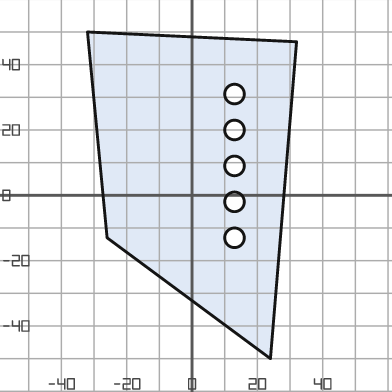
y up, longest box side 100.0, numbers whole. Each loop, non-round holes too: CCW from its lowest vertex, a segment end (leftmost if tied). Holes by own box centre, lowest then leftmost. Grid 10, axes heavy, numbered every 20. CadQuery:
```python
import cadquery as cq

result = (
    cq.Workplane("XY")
    .moveTo(24.0, -50.0)
    .lineTo(32.0, 47.0)
    .lineTo(-32.0, 50.0)
    .lineTo(-26.0, -13.0)
    .close()
    .moveTo(13.0, -13.0)
    .circle(3.0)
    .moveTo(13.0, -2.0)
    .circle(3.0)
    .moveTo(13.0, 9.0)
    .circle(3.0)
    .moveTo(13.0, 20.0)
    .circle(3.0)
    .moveTo(13.0, 31.0)
    .circle(3.0)
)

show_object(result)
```